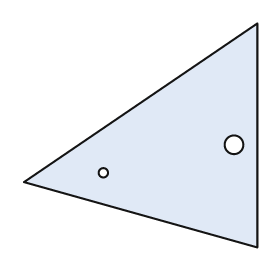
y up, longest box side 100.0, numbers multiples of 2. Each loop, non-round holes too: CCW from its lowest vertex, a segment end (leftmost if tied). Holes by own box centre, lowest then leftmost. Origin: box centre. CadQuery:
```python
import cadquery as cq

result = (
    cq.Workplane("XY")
    .moveTo(50.0, -48.0)
    .lineTo(50.0, 48.0)
    .lineTo(-50.0, -20.0)
    .close()
    .moveTo(-16.0, -16.0)
    .circle(2.0)
    .moveTo(40.0, -4.0)
    .circle(4.0)
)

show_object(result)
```